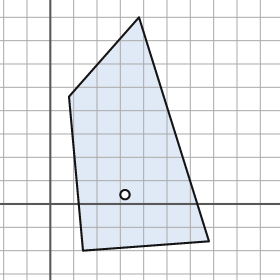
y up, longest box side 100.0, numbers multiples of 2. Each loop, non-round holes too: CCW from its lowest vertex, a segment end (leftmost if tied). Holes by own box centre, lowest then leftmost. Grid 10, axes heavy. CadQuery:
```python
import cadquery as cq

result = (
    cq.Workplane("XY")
    .moveTo(14.0, -20.0)
    .lineTo(68.0, -16.0)
    .lineTo(38.0, 80.0)
    .lineTo(8.0, 46.0)
    .close()
    .moveTo(32.0, 4.0)
    .circle(2.0)
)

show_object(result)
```